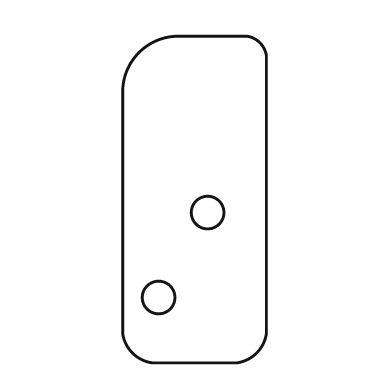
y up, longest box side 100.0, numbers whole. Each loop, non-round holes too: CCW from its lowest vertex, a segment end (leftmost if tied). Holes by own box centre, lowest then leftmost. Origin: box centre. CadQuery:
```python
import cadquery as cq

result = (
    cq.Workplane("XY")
    .moveTo(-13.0, -50.0)
    .lineTo(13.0, -50.0)
    .threePointArc((19.0, -47.0), (22.0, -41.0))
    .lineTo(22.0, 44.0)
    .threePointArc((20.0, 48.0), (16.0, 50.0))
    .lineTo(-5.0, 50.0)
    .threePointArc((-17.0, 45.0), (-22.0, 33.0))
    .lineTo(-22.0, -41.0)
    .threePointArc((-19.0, -47.0), (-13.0, -50.0))
    .close()
    .moveTo(-11.0, -30.0)
    .circle(5.0)
    .moveTo(4.0, -4.0)
    .circle(5.0)
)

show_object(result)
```